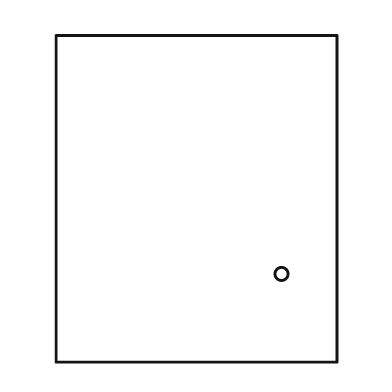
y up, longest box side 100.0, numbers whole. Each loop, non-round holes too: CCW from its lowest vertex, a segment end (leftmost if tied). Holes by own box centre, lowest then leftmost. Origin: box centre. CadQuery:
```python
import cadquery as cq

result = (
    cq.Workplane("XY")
    .moveTo(-43.0, -50.0)
    .lineTo(43.0, -50.0)
    .lineTo(43.0, 50.0)
    .lineTo(-43.0, 50.0)
    .close()
    .moveTo(26.0, -23.0)
    .circle(2.0)
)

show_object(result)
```